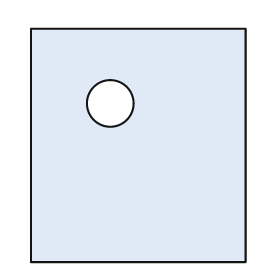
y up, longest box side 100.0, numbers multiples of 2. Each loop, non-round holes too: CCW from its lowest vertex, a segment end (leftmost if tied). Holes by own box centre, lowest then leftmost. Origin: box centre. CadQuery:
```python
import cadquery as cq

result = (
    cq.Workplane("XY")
    .moveTo(-46.0, -50.0)
    .lineTo(46.0, -50.0)
    .lineTo(46.0, 50.0)
    .lineTo(-46.0, 50.0)
    .close()
    .moveTo(-12.0, 18.0)
    .circle(10.0)
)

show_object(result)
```